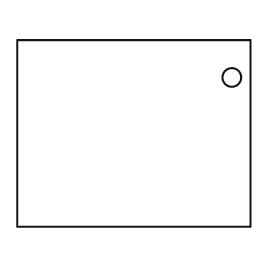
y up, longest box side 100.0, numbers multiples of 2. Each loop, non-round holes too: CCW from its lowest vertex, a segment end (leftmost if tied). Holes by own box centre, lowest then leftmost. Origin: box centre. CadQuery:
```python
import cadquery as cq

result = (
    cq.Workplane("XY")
    .moveTo(-50.0, -40.0)
    .lineTo(50.0, -40.0)
    .lineTo(50.0, 40.0)
    .lineTo(-50.0, 40.0)
    .close()
    .moveTo(42.0, 24.0)
    .circle(4.0)
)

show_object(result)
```